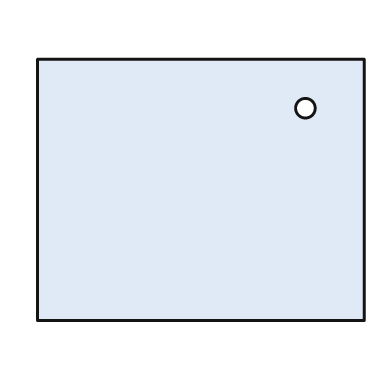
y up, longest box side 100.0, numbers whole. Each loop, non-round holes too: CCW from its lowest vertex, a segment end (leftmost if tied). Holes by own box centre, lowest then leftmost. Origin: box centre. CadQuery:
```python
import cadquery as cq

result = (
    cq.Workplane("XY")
    .moveTo(-50.0, -40.0)
    .lineTo(50.0, -40.0)
    .lineTo(50.0, 40.0)
    .lineTo(-50.0, 40.0)
    .close()
    .moveTo(32.0, 25.0)
    .circle(3.0)
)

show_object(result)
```